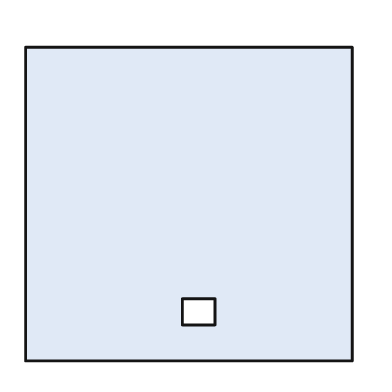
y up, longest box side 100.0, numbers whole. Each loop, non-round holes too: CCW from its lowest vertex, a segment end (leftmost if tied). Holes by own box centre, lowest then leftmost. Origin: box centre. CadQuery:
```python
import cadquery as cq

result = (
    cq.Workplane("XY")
    .moveTo(-50.0, -48.0)
    .lineTo(50.0, -48.0)
    .lineTo(50.0, 48.0)
    .lineTo(-50.0, 48.0)
    .close()
    .moveTo(-2.0, -37.0)
    .lineTo(8.0, -37.0)
    .lineTo(8.0, -29.0)
    .lineTo(-2.0, -29.0)
    .close()
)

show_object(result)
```